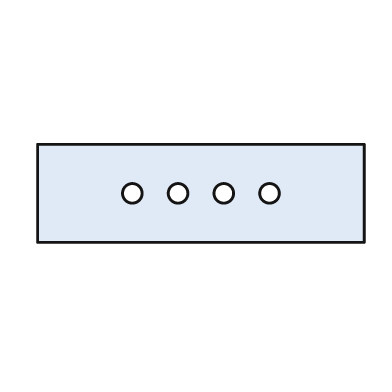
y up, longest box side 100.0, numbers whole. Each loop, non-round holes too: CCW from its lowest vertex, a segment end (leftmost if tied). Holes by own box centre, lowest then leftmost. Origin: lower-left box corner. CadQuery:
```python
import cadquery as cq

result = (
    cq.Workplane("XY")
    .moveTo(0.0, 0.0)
    .lineTo(100.0, 0.0)
    .lineTo(100.0, 30.0)
    .lineTo(0.0, 30.0)
    .close()
    .moveTo(29.0, 15.0)
    .circle(3.0)
    .moveTo(43.0, 15.0)
    .circle(3.0)
    .moveTo(57.0, 15.0)
    .circle(3.0)
    .moveTo(71.0, 15.0)
    .circle(3.0)
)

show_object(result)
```